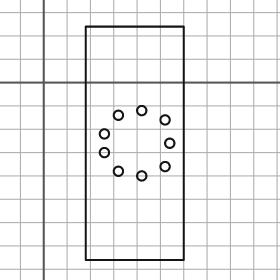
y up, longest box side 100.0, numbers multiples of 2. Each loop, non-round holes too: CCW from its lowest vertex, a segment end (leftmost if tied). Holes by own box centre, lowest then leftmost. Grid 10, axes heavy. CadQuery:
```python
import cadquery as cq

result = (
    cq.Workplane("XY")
    .moveTo(18.0, -76.0)
    .lineTo(60.0, -76.0)
    .lineTo(60.0, 24.0)
    .lineTo(18.0, 24.0)
    .close()
    .moveTo(42.0, -40.0)
    .circle(2.0)
    .moveTo(32.0, -38.0)
    .circle(2.0)
    .moveTo(52.0, -36.0)
    .circle(2.0)
    .moveTo(26.0, -30.0)
    .circle(2.0)
    .moveTo(54.0, -26.0)
    .circle(2.0)
    .moveTo(26.0, -22.0)
    .circle(2.0)
    .moveTo(52.0, -16.0)
    .circle(2.0)
    .moveTo(32.0, -14.0)
    .circle(2.0)
    .moveTo(42.0, -12.0)
    .circle(2.0)
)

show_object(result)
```